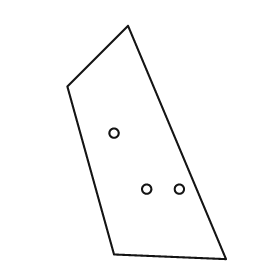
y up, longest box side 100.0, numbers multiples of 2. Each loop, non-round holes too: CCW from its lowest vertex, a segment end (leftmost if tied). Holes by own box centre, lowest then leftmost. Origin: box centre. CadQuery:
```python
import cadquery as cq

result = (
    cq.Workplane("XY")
    .moveTo(34.0, -50.0)
    .lineTo(-8.0, 50.0)
    .lineTo(-34.0, 24.0)
    .lineTo(-14.0, -48.0)
    .close()
    .moveTo(0.0, -20.0)
    .circle(2.0)
    .moveTo(14.0, -20.0)
    .circle(2.0)
    .moveTo(-14.0, 4.0)
    .circle(2.0)
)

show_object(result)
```